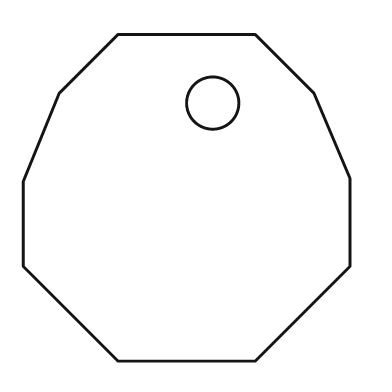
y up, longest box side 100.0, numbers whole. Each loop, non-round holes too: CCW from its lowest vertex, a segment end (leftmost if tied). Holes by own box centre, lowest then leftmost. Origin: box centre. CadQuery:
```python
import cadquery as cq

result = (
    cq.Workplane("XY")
    .moveTo(-21.0, -50.0)
    .lineTo(21.0, -50.0)
    .lineTo(50.0, -21.0)
    .lineTo(50.0, 6.0)
    .lineTo(39.0, 32.0)
    .lineTo(21.0, 50.0)
    .lineTo(-21.0, 50.0)
    .lineTo(-39.0, 32.0)
    .lineTo(-50.0, 5.0)
    .lineTo(-50.0, -21.0)
    .close()
    .moveTo(8.0, 29.0)
    .circle(8.0)
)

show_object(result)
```